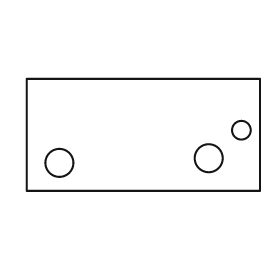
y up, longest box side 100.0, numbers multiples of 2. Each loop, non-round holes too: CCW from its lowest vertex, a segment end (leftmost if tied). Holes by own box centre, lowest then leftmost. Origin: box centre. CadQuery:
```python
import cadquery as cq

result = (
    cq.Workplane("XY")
    .moveTo(-50.0, -24.0)
    .lineTo(50.0, -24.0)
    .lineTo(50.0, 24.0)
    .lineTo(-50.0, 24.0)
    .close()
    .moveTo(-36.0, -12.0)
    .circle(6.0)
    .moveTo(28.0, -10.0)
    .circle(6.0)
    .moveTo(42.0, 2.0)
    .circle(4.0)
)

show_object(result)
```